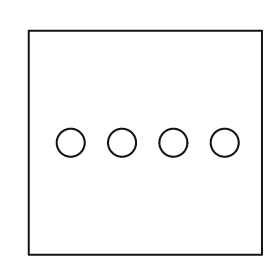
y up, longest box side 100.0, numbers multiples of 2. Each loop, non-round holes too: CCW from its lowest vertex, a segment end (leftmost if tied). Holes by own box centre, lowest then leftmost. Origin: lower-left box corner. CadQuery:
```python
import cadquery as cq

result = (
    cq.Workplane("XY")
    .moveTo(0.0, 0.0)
    .lineTo(100.0, 0.0)
    .lineTo(100.0, 96.0)
    .lineTo(0.0, 96.0)
    .close()
    .moveTo(18.0, 48.0)
    .circle(6.0)
    .moveTo(40.0, 48.0)
    .circle(6.0)
    .moveTo(62.0, 48.0)
    .circle(6.0)
    .moveTo(84.0, 48.0)
    .circle(6.0)
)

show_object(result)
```